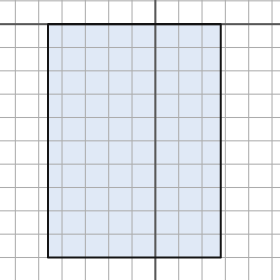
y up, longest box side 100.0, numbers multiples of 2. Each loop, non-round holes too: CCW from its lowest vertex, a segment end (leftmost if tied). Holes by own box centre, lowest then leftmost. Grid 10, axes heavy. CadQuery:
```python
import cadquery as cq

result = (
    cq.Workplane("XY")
    .moveTo(-46.0, -100.0)
    .lineTo(28.0, -100.0)
    .lineTo(28.0, 0.0)
    .lineTo(-46.0, 0.0)
    .close()
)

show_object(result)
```